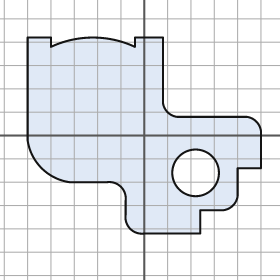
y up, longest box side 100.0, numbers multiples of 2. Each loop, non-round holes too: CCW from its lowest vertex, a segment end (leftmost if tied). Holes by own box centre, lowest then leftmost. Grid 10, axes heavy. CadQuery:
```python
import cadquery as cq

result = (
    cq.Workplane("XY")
    .moveTo(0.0, -42.0)
    .lineTo(24.0, -42.0)
    .lineTo(24.0, -32.0)
    .lineTo(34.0, -32.0)
    .threePointArc((38.0, -30.0), (40.0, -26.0))
    .lineTo(40.0, -14.0)
    .lineTo(50.0, -14.0)
    .lineTo(50.0, 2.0)
    .threePointArc((48.0, 6.0), (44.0, 8.0))
    .lineTo(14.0, 8.0)
    .threePointArc((10.0, 10.0), (8.0, 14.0))
    .lineTo(8.0, 42.0)
    .lineTo(-4.0, 42.0)
    .lineTo(-4.0, 38.0)
    .threePointArc((-22.0, 42.0), (-40.0, 38.0))
    .lineTo(-40.0, 42.0)
    .lineTo(-50.0, 42.0)
    .lineTo(-50.0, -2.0)
    .threePointArc((-44.0, -14.0), (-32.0, -20.0))
    .lineTo(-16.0, -20.0)
    .threePointArc((-10.0, -22.0), (-8.0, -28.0))
    .lineTo(-8.0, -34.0)
    .threePointArc((-6.0, -40.0), (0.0, -42.0))
    .close()
    .moveTo(22.0, -16.0)
    .circle(10.0)
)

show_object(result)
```